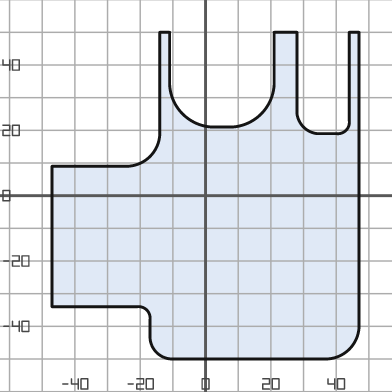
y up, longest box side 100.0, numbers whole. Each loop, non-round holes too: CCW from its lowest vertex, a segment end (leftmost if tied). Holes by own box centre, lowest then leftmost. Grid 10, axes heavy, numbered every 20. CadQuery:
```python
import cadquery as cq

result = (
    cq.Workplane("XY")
    .moveTo(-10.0, -50.0)
    .lineTo(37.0, -50.0)
    .threePointArc((44.0, -47.0), (47.0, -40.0))
    .lineTo(47.0, 50.0)
    .lineTo(44.0, 50.0)
    .lineTo(44.0, 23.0)
    .threePointArc((43.0, 20.0), (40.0, 19.0))
    .lineTo(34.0, 19.0)
    .threePointArc((30.0, 21.0), (28.0, 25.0))
    .lineTo(28.0, 50.0)
    .lineTo(21.0, 50.0)
    .lineTo(21.0, 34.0)
    .threePointArc((17.0, 25.0), (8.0, 21.0))
    .lineTo(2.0, 21.0)
    .threePointArc((-7.0, 25.0), (-11.0, 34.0))
    .lineTo(-11.0, 50.0)
    .lineTo(-14.0, 50.0)
    .lineTo(-14.0, 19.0)
    .threePointArc((-17.0, 12.0), (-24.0, 9.0))
    .lineTo(-47.0, 9.0)
    .lineTo(-47.0, -34.0)
    .lineTo(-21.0, -34.0)
    .threePointArc((-18.0, -35.0), (-17.0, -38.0))
    .lineTo(-17.0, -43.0)
    .threePointArc((-15.0, -48.0), (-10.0, -50.0))
    .close()
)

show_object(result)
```